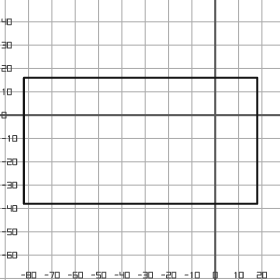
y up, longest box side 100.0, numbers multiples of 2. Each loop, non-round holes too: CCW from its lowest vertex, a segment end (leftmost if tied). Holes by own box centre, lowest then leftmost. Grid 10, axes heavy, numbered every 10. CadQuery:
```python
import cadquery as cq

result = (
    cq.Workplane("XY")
    .moveTo(-82.0, -38.0)
    .lineTo(18.0, -38.0)
    .lineTo(18.0, 16.0)
    .lineTo(-82.0, 16.0)
    .close()
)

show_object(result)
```